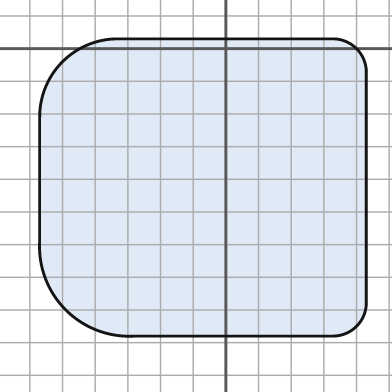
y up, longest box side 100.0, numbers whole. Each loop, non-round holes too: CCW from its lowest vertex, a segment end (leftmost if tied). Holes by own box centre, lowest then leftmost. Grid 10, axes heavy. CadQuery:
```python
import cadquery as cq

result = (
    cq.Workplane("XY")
    .moveTo(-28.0, -88.0)
    .lineTo(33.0, -88.0)
    .threePointArc((40.0, -85.0), (43.0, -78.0))
    .lineTo(43.0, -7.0)
    .threePointArc((40.0, 0.0), (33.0, 3.0))
    .lineTo(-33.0, 3.0)
    .threePointArc((-50.0, -4.0), (-57.0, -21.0))
    .lineTo(-57.0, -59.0)
    .threePointArc((-49.0, -80.0), (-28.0, -88.0))
    .close()
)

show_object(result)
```